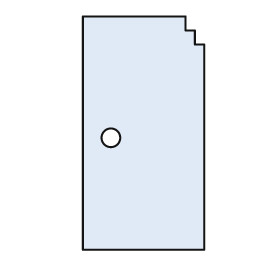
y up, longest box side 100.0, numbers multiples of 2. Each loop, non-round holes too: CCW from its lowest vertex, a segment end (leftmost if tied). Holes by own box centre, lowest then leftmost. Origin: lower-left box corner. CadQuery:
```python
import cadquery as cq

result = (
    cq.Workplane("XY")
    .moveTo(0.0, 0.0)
    .lineTo(52.0, 0.0)
    .lineTo(52.0, 88.0)
    .lineTo(48.0, 88.0)
    .lineTo(48.0, 94.0)
    .lineTo(44.0, 94.0)
    .lineTo(44.0, 100.0)
    .lineTo(0.0, 100.0)
    .close()
    .moveTo(12.0, 48.0)
    .circle(4.0)
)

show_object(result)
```